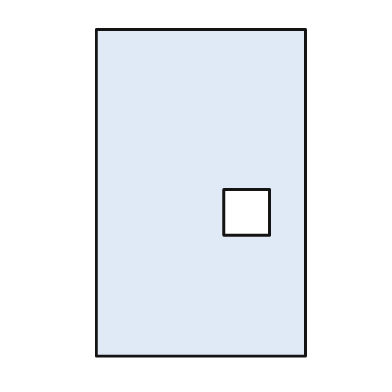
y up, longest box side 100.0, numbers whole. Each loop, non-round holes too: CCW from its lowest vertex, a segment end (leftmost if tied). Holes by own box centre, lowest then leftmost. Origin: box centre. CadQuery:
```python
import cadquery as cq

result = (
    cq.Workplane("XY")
    .moveTo(-32.0, -50.0)
    .lineTo(32.0, -50.0)
    .lineTo(32.0, 50.0)
    .lineTo(-32.0, 50.0)
    .close()
    .moveTo(7.0, -13.0)
    .lineTo(21.0, -13.0)
    .lineTo(21.0, 1.0)
    .lineTo(7.0, 1.0)
    .close()
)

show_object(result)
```